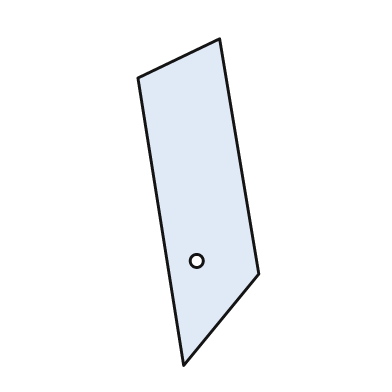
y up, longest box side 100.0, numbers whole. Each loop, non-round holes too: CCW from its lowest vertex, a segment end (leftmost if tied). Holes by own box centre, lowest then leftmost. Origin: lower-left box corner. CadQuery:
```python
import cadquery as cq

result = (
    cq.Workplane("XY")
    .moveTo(14.0, 0.0)
    .lineTo(37.0, 28.0)
    .lineTo(25.0, 100.0)
    .lineTo(0.0, 88.0)
    .close()
    .moveTo(18.0, 32.0)
    .circle(2.0)
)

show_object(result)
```